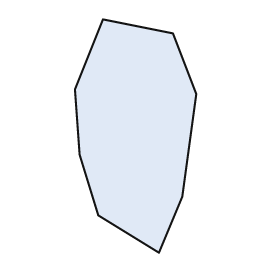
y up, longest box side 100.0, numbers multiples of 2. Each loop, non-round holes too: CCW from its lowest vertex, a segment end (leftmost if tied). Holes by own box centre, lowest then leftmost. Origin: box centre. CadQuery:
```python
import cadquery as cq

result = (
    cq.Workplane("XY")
    .moveTo(10.0, -50.0)
    .lineTo(20.0, -26.0)
    .lineTo(26.0, 18.0)
    .lineTo(16.0, 44.0)
    .lineTo(-14.0, 50.0)
    .lineTo(-26.0, 20.0)
    .lineTo(-24.0, -8.0)
    .lineTo(-16.0, -34.0)
    .close()
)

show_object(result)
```